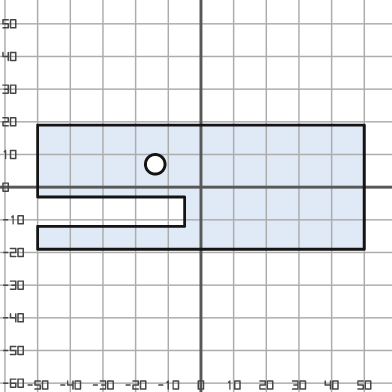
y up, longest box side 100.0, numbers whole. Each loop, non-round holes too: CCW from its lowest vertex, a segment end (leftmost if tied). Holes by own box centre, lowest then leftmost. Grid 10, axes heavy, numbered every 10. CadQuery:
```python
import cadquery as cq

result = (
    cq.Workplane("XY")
    .moveTo(-50.0, -19.0)
    .lineTo(50.0, -19.0)
    .lineTo(50.0, 19.0)
    .lineTo(-50.0, 19.0)
    .lineTo(-50.0, -3.0)
    .lineTo(-5.0, -3.0)
    .lineTo(-5.0, -12.0)
    .lineTo(-50.0, -12.0)
    .close()
    .moveTo(-14.0, 7.0)
    .circle(3.0)
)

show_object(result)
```